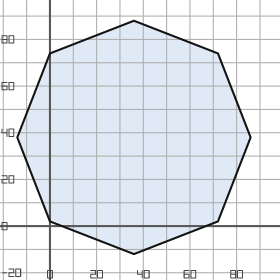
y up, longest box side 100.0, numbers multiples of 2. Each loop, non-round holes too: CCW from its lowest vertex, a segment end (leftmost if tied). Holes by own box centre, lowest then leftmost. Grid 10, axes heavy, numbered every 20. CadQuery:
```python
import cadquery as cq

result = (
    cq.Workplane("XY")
    .moveTo(36.0, -12.0)
    .lineTo(72.0, 2.0)
    .lineTo(86.0, 38.0)
    .lineTo(72.0, 74.0)
    .lineTo(36.0, 88.0)
    .lineTo(0.0, 74.0)
    .lineTo(-14.0, 38.0)
    .lineTo(0.0, 2.0)
    .close()
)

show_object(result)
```